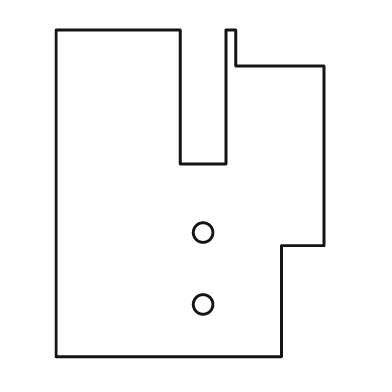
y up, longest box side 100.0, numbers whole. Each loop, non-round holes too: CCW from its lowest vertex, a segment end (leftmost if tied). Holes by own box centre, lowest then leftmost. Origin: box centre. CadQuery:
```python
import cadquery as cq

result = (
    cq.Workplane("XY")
    .moveTo(-41.0, -50.0)
    .lineTo(28.0, -50.0)
    .lineTo(28.0, -16.0)
    .lineTo(41.0, -16.0)
    .lineTo(41.0, 39.0)
    .lineTo(14.0, 39.0)
    .lineTo(14.0, 50.0)
    .lineTo(11.0, 50.0)
    .lineTo(11.0, 9.0)
    .lineTo(-3.0, 9.0)
    .lineTo(-3.0, 50.0)
    .lineTo(-41.0, 50.0)
    .close()
    .moveTo(4.0, -34.0)
    .circle(3.0)
    .moveTo(4.0, -12.0)
    .circle(3.0)
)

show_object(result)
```